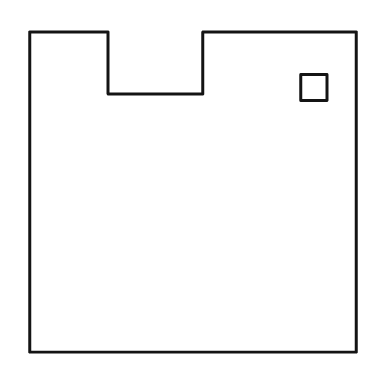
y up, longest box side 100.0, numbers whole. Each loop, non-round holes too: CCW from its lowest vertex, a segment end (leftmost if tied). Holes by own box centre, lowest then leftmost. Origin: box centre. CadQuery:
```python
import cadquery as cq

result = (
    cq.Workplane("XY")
    .moveTo(-50.0, -49.0)
    .lineTo(50.0, -49.0)
    .lineTo(50.0, 49.0)
    .lineTo(3.0, 49.0)
    .lineTo(3.0, 30.0)
    .lineTo(-26.0, 30.0)
    .lineTo(-26.0, 49.0)
    .lineTo(-50.0, 49.0)
    .close()
    .moveTo(33.0, 28.0)
    .lineTo(41.0, 28.0)
    .lineTo(41.0, 36.0)
    .lineTo(33.0, 36.0)
    .close()
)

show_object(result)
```